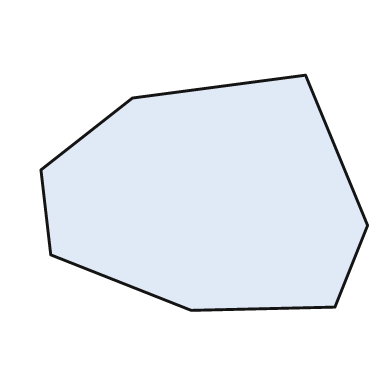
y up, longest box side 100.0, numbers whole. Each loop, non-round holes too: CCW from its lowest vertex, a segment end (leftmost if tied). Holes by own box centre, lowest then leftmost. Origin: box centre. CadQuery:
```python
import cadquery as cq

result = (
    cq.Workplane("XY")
    .moveTo(-4.0, -36.0)
    .lineTo(40.0, -35.0)
    .lineTo(50.0, -10.0)
    .lineTo(31.0, 36.0)
    .lineTo(-22.0, 29.0)
    .lineTo(-50.0, 7.0)
    .lineTo(-47.0, -19.0)
    .close()
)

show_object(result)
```